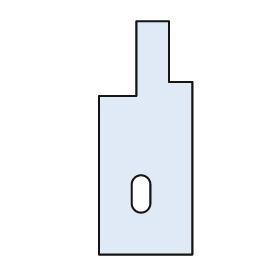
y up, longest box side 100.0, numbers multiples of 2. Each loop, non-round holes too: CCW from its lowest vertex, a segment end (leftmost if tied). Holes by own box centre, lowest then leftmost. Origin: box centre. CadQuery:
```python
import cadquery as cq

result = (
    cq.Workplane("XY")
    .moveTo(-20.0, -50.0)
    .lineTo(20.0, -50.0)
    .lineTo(20.0, 24.0)
    .lineTo(10.0, 24.0)
    .lineTo(10.0, 50.0)
    .lineTo(-4.0, 50.0)
    .lineTo(-4.0, 18.0)
    .lineTo(-20.0, 18.0)
    .close()
    .moveTo(-6.0, -28.0)
    .threePointArc((-2.0, -32.0), (2.0, -28.0))
    .lineTo(2.0, -20.0)
    .threePointArc((-2.0, -16.0), (-6.0, -20.0))
    .close()
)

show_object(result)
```